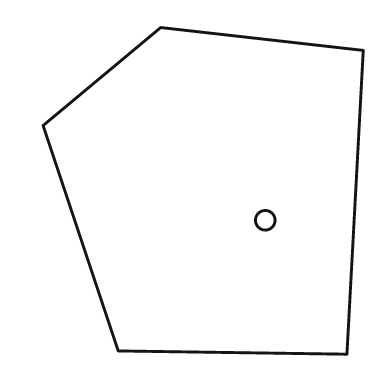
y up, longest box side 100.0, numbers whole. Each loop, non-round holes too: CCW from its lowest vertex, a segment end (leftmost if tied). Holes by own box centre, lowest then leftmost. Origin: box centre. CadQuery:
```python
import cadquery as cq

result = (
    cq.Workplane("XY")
    .moveTo(44.0, -50.0)
    .lineTo(49.0, 43.0)
    .lineTo(-13.0, 50.0)
    .lineTo(-49.0, 20.0)
    .lineTo(-26.0, -49.0)
    .close()
    .moveTo(19.0, -9.0)
    .circle(3.0)
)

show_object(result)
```